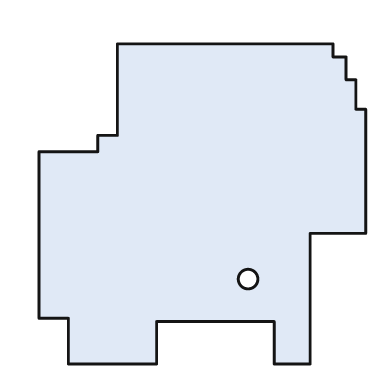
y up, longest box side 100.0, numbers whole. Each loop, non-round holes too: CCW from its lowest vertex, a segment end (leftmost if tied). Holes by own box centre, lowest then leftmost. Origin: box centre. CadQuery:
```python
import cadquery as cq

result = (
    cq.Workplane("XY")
    .moveTo(-41.0, -49.0)
    .lineTo(-14.0, -49.0)
    .lineTo(-14.0, -36.0)
    .lineTo(22.0, -36.0)
    .lineTo(22.0, -49.0)
    .lineTo(33.0, -49.0)
    .lineTo(33.0, -9.0)
    .lineTo(50.0, -9.0)
    .lineTo(50.0, 29.0)
    .lineTo(47.0, 29.0)
    .lineTo(47.0, 38.0)
    .lineTo(44.0, 38.0)
    .lineTo(44.0, 45.0)
    .lineTo(40.0, 45.0)
    .lineTo(40.0, 49.0)
    .lineTo(-26.0, 49.0)
    .lineTo(-26.0, 21.0)
    .lineTo(-32.0, 21.0)
    .lineTo(-32.0, 16.0)
    .lineTo(-50.0, 16.0)
    .lineTo(-50.0, -35.0)
    .lineTo(-41.0, -35.0)
    .close()
    .moveTo(14.0, -23.0)
    .circle(3.0)
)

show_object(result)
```